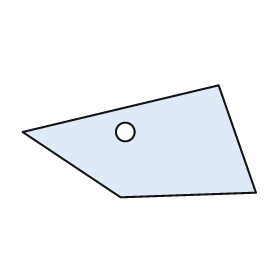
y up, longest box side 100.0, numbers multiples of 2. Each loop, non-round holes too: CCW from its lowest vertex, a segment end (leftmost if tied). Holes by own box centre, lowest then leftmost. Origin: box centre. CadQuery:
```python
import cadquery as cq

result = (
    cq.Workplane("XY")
    .moveTo(-8.0, -24.0)
    .lineTo(50.0, -22.0)
    .lineTo(34.0, 24.0)
    .lineTo(-50.0, 4.0)
    .close()
    .moveTo(-6.0, 4.0)
    .circle(4.0)
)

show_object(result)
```